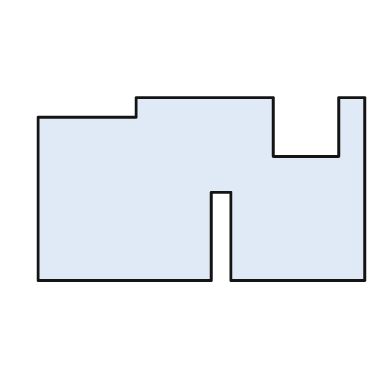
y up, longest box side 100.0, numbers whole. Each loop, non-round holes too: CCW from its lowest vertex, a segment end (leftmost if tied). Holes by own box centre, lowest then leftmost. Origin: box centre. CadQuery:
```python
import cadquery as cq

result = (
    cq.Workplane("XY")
    .moveTo(-50.0, -28.0)
    .lineTo(3.0, -28.0)
    .lineTo(3.0, -1.0)
    .lineTo(9.0, -1.0)
    .lineTo(9.0, -28.0)
    .lineTo(50.0, -28.0)
    .lineTo(50.0, 28.0)
    .lineTo(42.0, 28.0)
    .lineTo(42.0, 10.0)
    .lineTo(22.0, 10.0)
    .lineTo(22.0, 28.0)
    .lineTo(-20.0, 28.0)
    .lineTo(-20.0, 22.0)
    .lineTo(-50.0, 22.0)
    .close()
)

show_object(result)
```